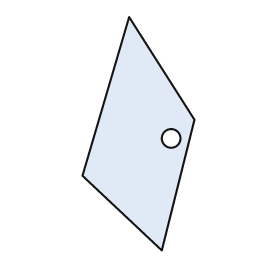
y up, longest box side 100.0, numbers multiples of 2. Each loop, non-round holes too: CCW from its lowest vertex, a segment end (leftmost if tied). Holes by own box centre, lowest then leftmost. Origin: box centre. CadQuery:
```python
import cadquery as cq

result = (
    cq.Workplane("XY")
    .moveTo(10.0, -50.0)
    .lineTo(24.0, 6.0)
    .lineTo(-4.0, 50.0)
    .lineTo(-24.0, -18.0)
    .close()
    .moveTo(14.0, -2.0)
    .circle(4.0)
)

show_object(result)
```